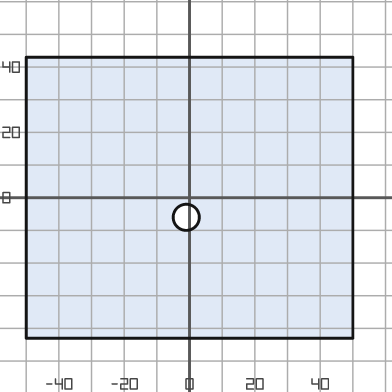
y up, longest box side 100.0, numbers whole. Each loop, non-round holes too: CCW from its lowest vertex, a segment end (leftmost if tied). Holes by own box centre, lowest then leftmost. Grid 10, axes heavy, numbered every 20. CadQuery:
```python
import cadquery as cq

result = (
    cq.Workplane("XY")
    .moveTo(-50.0, -43.0)
    .lineTo(50.0, -43.0)
    .lineTo(50.0, 43.0)
    .lineTo(-50.0, 43.0)
    .close()
    .moveTo(-1.0, -6.0)
    .circle(4.0)
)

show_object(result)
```